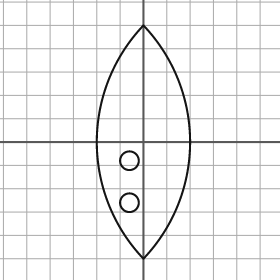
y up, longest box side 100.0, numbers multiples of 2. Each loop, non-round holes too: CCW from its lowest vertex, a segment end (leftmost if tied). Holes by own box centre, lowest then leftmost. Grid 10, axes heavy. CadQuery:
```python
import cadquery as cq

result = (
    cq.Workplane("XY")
    .moveTo(0.0, -50.0)
    .threePointArc((20.0, 0.0), (0.0, 50.0))
    .threePointArc((-20.0, 0.0), (0.0, -50.0))
    .close()
    .moveTo(-6.0, -26.0)
    .circle(4.0)
    .moveTo(-6.0, -8.0)
    .circle(4.0)
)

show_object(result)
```